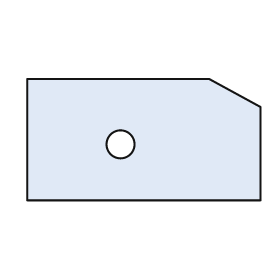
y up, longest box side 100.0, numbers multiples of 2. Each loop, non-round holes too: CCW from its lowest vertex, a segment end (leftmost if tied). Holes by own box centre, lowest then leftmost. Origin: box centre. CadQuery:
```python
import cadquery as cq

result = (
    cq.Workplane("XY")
    .moveTo(-50.0, -26.0)
    .lineTo(50.0, -26.0)
    .lineTo(50.0, 14.0)
    .lineTo(28.0, 26.0)
    .lineTo(-50.0, 26.0)
    .close()
    .moveTo(-10.0, -2.0)
    .circle(6.0)
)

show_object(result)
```